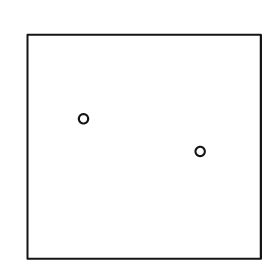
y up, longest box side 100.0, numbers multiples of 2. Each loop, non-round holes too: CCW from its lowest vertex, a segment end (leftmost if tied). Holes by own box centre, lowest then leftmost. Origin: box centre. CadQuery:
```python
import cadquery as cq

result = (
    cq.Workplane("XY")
    .moveTo(-50.0, -48.0)
    .lineTo(50.0, -48.0)
    .lineTo(50.0, 48.0)
    .lineTo(-50.0, 48.0)
    .close()
    .moveTo(24.0, -2.0)
    .circle(2.0)
    .moveTo(-26.0, 12.0)
    .circle(2.0)
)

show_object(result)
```